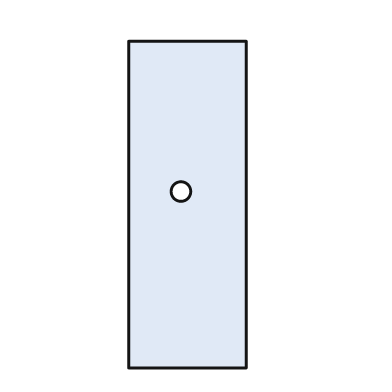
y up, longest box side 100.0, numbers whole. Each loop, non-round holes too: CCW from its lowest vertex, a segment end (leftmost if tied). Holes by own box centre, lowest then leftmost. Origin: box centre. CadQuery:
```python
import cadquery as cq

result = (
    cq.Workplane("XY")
    .moveTo(-18.0, -50.0)
    .lineTo(18.0, -50.0)
    .lineTo(18.0, 50.0)
    .lineTo(-18.0, 50.0)
    .close()
    .moveTo(-2.0, 4.0)
    .circle(3.0)
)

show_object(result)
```